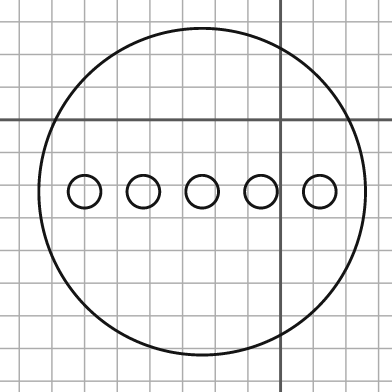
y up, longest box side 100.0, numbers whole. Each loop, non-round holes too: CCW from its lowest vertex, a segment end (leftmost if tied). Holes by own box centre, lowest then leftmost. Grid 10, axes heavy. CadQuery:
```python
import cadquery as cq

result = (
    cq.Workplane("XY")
    .moveTo(-24.0, -22.0)
    .circle(50.0)
    .moveTo(-60.0, -22.0)
    .circle(5.0)
    .moveTo(-42.0, -22.0)
    .circle(5.0)
    .moveTo(-24.0, -22.0)
    .circle(5.0)
    .moveTo(-6.0, -22.0)
    .circle(5.0)
    .moveTo(12.0, -22.0)
    .circle(5.0)
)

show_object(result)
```